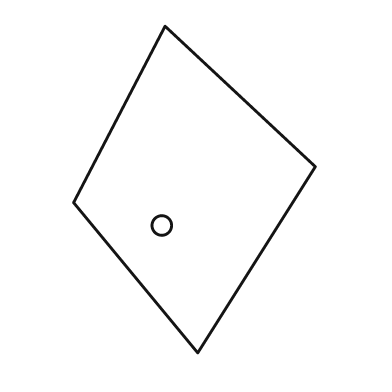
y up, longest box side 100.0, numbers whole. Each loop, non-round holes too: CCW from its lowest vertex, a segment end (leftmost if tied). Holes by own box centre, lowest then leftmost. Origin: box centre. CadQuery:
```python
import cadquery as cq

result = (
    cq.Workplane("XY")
    .moveTo(1.0, -50.0)
    .lineTo(37.0, 7.0)
    .lineTo(-9.0, 50.0)
    .lineTo(-37.0, -4.0)
    .close()
    .moveTo(-10.0, -11.0)
    .circle(3.0)
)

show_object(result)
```